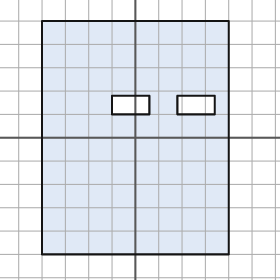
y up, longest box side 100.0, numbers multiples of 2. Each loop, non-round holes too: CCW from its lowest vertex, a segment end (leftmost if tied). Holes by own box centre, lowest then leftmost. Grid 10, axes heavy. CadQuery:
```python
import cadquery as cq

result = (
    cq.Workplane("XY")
    .moveTo(-40.0, -50.0)
    .lineTo(40.0, -50.0)
    .lineTo(40.0, 50.0)
    .lineTo(-40.0, 50.0)
    .close()
    .moveTo(-10.0, 10.0)
    .lineTo(6.0, 10.0)
    .lineTo(6.0, 18.0)
    .lineTo(-10.0, 18.0)
    .close()
    .moveTo(18.0, 10.0)
    .lineTo(34.0, 10.0)
    .lineTo(34.0, 18.0)
    .lineTo(18.0, 18.0)
    .close()
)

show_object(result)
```